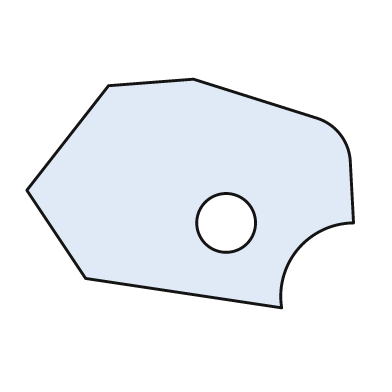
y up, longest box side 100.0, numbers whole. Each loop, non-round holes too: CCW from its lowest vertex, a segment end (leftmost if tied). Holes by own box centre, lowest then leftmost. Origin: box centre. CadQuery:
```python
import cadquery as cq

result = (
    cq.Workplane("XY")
    .moveTo(28.0, -35.0)
    .threePointArc((33.0, -17.0), (50.0, -9.0))
    .lineTo(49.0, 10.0)
    .threePointArc((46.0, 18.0), (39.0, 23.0))
    .lineTo(1.0, 35.0)
    .lineTo(-25.0, 33.0)
    .lineTo(-50.0, 1.0)
    .lineTo(-32.0, -26.0)
    .close()
    .moveTo(11.0, -9.0)
    .circle(9.0)
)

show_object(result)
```